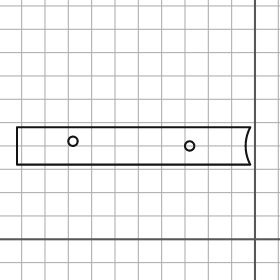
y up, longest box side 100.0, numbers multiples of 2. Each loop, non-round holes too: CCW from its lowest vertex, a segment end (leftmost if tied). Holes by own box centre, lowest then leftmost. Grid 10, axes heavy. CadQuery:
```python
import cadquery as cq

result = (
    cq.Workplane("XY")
    .moveTo(-102.0, 32.0)
    .lineTo(-2.0, 32.0)
    .threePointArc((-4.0, 40.0), (-2.0, 48.0))
    .lineTo(-102.0, 48.0)
    .close()
    .moveTo(-28.0, 40.0)
    .circle(2.0)
    .moveTo(-78.0, 42.0)
    .circle(2.0)
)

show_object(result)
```